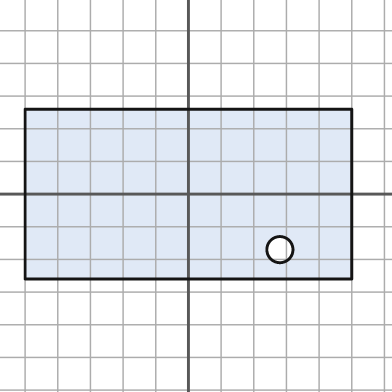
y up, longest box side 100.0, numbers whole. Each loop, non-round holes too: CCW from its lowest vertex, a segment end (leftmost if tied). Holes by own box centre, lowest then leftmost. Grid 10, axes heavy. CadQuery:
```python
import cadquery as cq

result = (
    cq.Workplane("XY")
    .moveTo(-50.0, -26.0)
    .lineTo(50.0, -26.0)
    .lineTo(50.0, 26.0)
    .lineTo(-50.0, 26.0)
    .close()
    .moveTo(28.0, -17.0)
    .circle(4.0)
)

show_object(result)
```